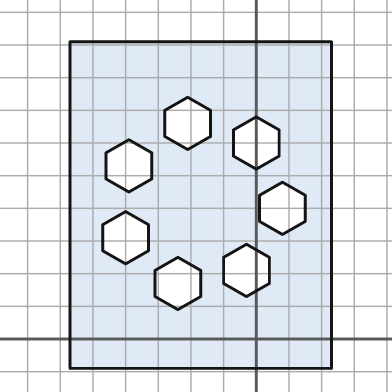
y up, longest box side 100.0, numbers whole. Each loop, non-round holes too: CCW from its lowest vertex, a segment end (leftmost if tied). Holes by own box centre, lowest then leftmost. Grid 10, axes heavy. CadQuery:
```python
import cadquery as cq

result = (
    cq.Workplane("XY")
    .moveTo(-57.0, -9.0)
    .lineTo(23.0, -9.0)
    .lineTo(23.0, 91.0)
    .lineTo(-57.0, 91.0)
    .close()
    .moveTo(-24.0, 9.0)
    .lineTo(-17.0, 13.0)
    .lineTo(-17.0, 21.0)
    .lineTo(-24.0, 25.0)
    .lineTo(-31.0, 21.0)
    .lineTo(-31.0, 13.0)
    .close()
    .moveTo(-3.0, 13.0)
    .lineTo(4.0, 17.0)
    .lineTo(4.0, 25.0)
    .lineTo(-3.0, 29.0)
    .lineTo(-10.0, 25.0)
    .lineTo(-10.0, 17.0)
    .close()
    .moveTo(-40.0, 23.0)
    .lineTo(-33.0, 27.0)
    .lineTo(-33.0, 35.0)
    .lineTo(-40.0, 39.0)
    .lineTo(-47.0, 35.0)
    .lineTo(-47.0, 27.0)
    .close()
    .moveTo(8.0, 32.0)
    .lineTo(15.0, 36.0)
    .lineTo(15.0, 44.0)
    .lineTo(8.0, 48.0)
    .lineTo(1.0, 44.0)
    .lineTo(1.0, 36.0)
    .close()
    .moveTo(-39.0, 45.0)
    .lineTo(-32.0, 49.0)
    .lineTo(-32.0, 57.0)
    .lineTo(-39.0, 61.0)
    .lineTo(-46.0, 57.0)
    .lineTo(-46.0, 49.0)
    .close()
    .moveTo(0.0, 52.0)
    .lineTo(7.0, 56.0)
    .lineTo(7.0, 64.0)
    .lineTo(0.0, 68.0)
    .lineTo(-7.0, 64.0)
    .lineTo(-7.0, 56.0)
    .close()
    .moveTo(-21.0, 58.0)
    .lineTo(-14.0, 62.0)
    .lineTo(-14.0, 70.0)
    .lineTo(-21.0, 74.0)
    .lineTo(-28.0, 70.0)
    .lineTo(-28.0, 62.0)
    .close()
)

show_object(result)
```